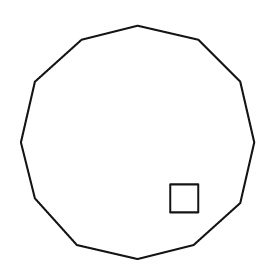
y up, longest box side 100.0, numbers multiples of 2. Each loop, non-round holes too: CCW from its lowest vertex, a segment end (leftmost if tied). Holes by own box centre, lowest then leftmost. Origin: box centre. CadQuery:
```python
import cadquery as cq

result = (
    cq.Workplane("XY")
    .moveTo(0.0, -50.0)
    .lineTo(24.0, -44.0)
    .lineTo(44.0, -26.0)
    .lineTo(50.0, 0.0)
    .lineTo(44.0, 26.0)
    .lineTo(26.0, 44.0)
    .lineTo(0.0, 50.0)
    .lineTo(-24.0, 44.0)
    .lineTo(-44.0, 26.0)
    .lineTo(-50.0, 0.0)
    .lineTo(-44.0, -24.0)
    .lineTo(-26.0, -44.0)
    .close()
    .moveTo(14.0, -30.0)
    .lineTo(26.0, -30.0)
    .lineTo(26.0, -18.0)
    .lineTo(14.0, -18.0)
    .close()
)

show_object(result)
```